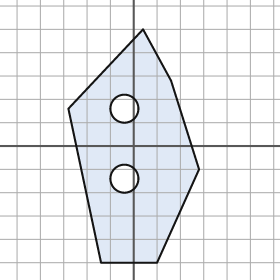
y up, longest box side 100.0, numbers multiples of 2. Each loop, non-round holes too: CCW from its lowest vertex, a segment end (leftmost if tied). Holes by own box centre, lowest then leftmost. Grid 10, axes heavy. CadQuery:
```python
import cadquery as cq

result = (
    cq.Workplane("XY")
    .moveTo(-14.0, -50.0)
    .lineTo(10.0, -50.0)
    .lineTo(28.0, -10.0)
    .lineTo(16.0, 28.0)
    .lineTo(4.0, 50.0)
    .lineTo(-28.0, 16.0)
    .close()
    .moveTo(-4.0, -14.0)
    .circle(6.0)
    .moveTo(-4.0, 16.0)
    .circle(6.0)
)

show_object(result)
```